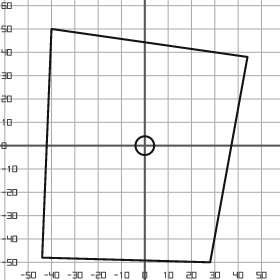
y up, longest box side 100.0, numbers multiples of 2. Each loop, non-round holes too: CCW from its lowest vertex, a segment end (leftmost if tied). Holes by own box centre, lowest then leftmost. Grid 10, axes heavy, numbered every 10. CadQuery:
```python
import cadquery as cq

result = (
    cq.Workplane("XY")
    .moveTo(28.0, -50.0)
    .lineTo(44.0, 38.0)
    .lineTo(-40.0, 50.0)
    .lineTo(-44.0, -48.0)
    .close()
    .moveTo(0.0, 0.0)
    .circle(4.0)
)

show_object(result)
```